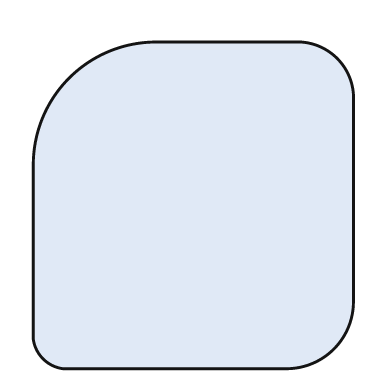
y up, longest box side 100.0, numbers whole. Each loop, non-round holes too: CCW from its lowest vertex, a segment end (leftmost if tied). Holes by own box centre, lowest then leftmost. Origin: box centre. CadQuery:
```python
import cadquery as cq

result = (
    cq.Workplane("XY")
    .moveTo(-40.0, -50.0)
    .lineTo(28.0, -50.0)
    .threePointArc((43.0, -44.0), (49.0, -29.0))
    .lineTo(49.0, 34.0)
    .threePointArc((44.0, 45.0), (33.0, 50.0))
    .lineTo(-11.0, 50.0)
    .threePointArc((-38.0, 39.0), (-49.0, 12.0))
    .lineTo(-49.0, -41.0)
    .threePointArc((-46.0, -47.0), (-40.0, -50.0))
    .close()
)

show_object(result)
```